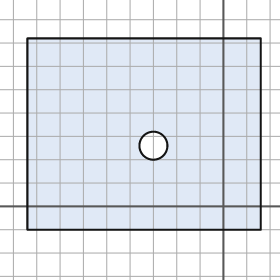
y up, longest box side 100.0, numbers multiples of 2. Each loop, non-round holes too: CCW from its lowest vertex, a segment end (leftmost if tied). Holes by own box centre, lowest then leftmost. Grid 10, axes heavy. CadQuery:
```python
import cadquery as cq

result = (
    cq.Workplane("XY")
    .moveTo(-84.0, -10.0)
    .lineTo(16.0, -10.0)
    .lineTo(16.0, 72.0)
    .lineTo(-84.0, 72.0)
    .close()
    .moveTo(-30.0, 26.0)
    .circle(6.0)
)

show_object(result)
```